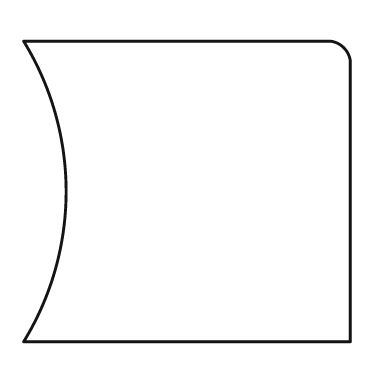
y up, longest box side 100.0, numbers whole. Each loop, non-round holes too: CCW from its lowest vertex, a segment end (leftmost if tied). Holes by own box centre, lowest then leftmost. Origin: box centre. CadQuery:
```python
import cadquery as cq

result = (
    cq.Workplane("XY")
    .moveTo(-50.0, -46.0)
    .lineTo(50.0, -46.0)
    .lineTo(50.0, 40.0)
    .threePointArc((48.0, 44.0), (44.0, 46.0))
    .lineTo(-50.0, 46.0)
    .threePointArc((-37.0, 0.0), (-50.0, -46.0))
    .close()
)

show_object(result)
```